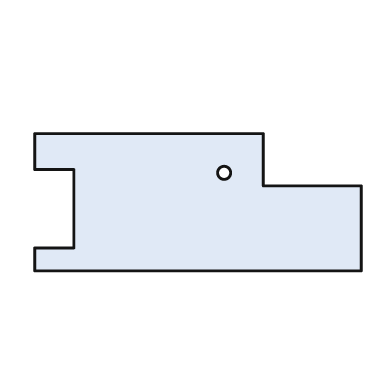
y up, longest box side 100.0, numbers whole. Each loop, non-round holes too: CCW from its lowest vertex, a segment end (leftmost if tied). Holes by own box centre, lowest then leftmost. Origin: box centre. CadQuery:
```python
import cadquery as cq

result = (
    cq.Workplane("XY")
    .moveTo(-50.0, -21.0)
    .lineTo(50.0, -21.0)
    .lineTo(50.0, 5.0)
    .lineTo(20.0, 5.0)
    .lineTo(20.0, 21.0)
    .lineTo(-50.0, 21.0)
    .lineTo(-50.0, 10.0)
    .lineTo(-38.0, 10.0)
    .lineTo(-38.0, -14.0)
    .lineTo(-50.0, -14.0)
    .close()
    .moveTo(8.0, 9.0)
    .circle(2.0)
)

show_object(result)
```